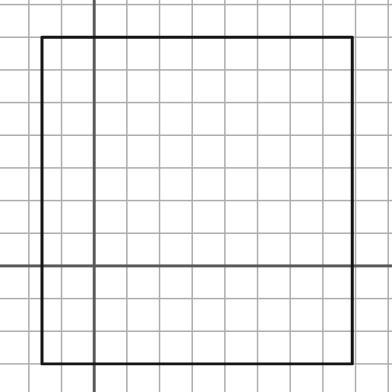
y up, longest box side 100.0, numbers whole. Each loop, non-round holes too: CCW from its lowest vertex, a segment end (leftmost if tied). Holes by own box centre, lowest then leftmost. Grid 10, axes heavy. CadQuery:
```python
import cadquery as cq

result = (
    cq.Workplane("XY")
    .moveTo(-16.0, -30.0)
    .lineTo(79.0, -30.0)
    .lineTo(79.0, 70.0)
    .lineTo(-16.0, 70.0)
    .close()
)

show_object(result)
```